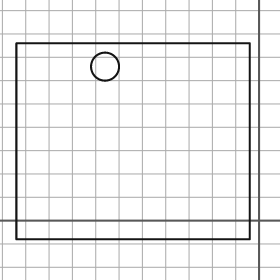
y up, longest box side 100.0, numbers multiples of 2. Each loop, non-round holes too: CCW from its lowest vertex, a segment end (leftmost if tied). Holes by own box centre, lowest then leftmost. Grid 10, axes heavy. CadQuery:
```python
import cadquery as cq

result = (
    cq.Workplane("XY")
    .moveTo(-104.0, -8.0)
    .lineTo(-4.0, -8.0)
    .lineTo(-4.0, 76.0)
    .lineTo(-104.0, 76.0)
    .close()
    .moveTo(-66.0, 66.0)
    .circle(6.0)
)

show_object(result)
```